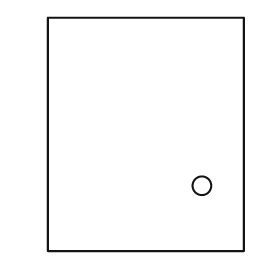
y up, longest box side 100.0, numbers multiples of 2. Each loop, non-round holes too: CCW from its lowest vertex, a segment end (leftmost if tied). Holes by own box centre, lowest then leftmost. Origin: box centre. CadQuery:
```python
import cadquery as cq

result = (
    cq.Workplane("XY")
    .moveTo(-42.0, -50.0)
    .lineTo(42.0, -50.0)
    .lineTo(42.0, 50.0)
    .lineTo(-42.0, 50.0)
    .close()
    .moveTo(24.0, -22.0)
    .circle(4.0)
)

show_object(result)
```